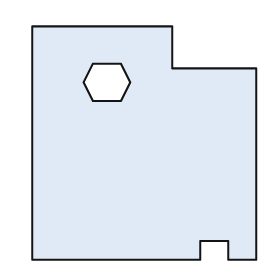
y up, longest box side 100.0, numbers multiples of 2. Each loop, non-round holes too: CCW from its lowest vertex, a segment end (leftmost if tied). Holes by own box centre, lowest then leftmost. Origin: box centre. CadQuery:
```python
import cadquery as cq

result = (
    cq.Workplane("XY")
    .moveTo(-48.0, -50.0)
    .lineTo(24.0, -50.0)
    .lineTo(24.0, -42.0)
    .lineTo(36.0, -42.0)
    .lineTo(36.0, -50.0)
    .lineTo(48.0, -50.0)
    .lineTo(48.0, 32.0)
    .lineTo(12.0, 32.0)
    .lineTo(12.0, 50.0)
    .lineTo(-48.0, 50.0)
    .close()
    .moveTo(-22.0, 18.0)
    .lineTo(-10.0, 18.0)
    .lineTo(-6.0, 26.0)
    .lineTo(-10.0, 34.0)
    .lineTo(-22.0, 34.0)
    .lineTo(-26.0, 26.0)
    .close()
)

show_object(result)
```